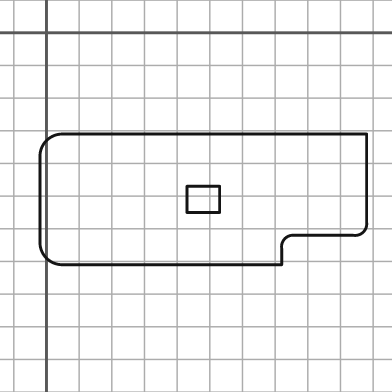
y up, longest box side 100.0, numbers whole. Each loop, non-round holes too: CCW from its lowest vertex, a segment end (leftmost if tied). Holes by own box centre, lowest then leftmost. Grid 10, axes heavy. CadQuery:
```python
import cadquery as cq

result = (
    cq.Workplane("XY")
    .moveTo(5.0, -71.0)
    .lineTo(72.0, -71.0)
    .lineTo(72.0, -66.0)
    .threePointArc((73.0, -63.0), (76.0, -62.0))
    .lineTo(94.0, -62.0)
    .threePointArc((97.0, -61.0), (98.0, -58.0))
    .lineTo(98.0, -31.0)
    .lineTo(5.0, -31.0)
    .threePointArc((0.0, -33.0), (-2.0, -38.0))
    .lineTo(-2.0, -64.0)
    .threePointArc((0.0, -69.0), (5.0, -71.0))
    .close()
    .moveTo(43.0, -55.0)
    .lineTo(53.0, -55.0)
    .lineTo(53.0, -47.0)
    .lineTo(43.0, -47.0)
    .close()
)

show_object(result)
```